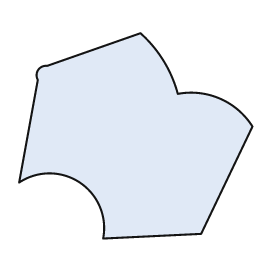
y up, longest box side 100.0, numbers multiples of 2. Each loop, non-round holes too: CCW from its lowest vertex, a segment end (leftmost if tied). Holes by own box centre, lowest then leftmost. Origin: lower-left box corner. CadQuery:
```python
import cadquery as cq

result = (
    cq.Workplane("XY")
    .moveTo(36.0, 0.0)
    .lineTo(78.0, 2.0)
    .lineTo(100.0, 48.0)
    .threePointArc((86.0, 60.0), (68.0, 62.0))
    .threePointArc((62.0, 76.0), (52.0, 88.0))
    .lineTo(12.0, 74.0)
    .threePointArc((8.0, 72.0), (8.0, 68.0))
    .lineTo(0.0, 24.0)
    .threePointArc((26.0, 24.0), (36.0, 0.0))
    .close()
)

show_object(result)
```